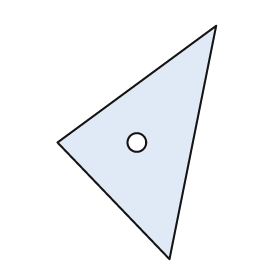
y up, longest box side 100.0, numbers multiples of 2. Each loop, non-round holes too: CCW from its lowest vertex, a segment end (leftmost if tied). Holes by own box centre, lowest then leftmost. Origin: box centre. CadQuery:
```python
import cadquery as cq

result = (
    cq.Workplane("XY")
    .moveTo(14.0, -50.0)
    .lineTo(34.0, 50.0)
    .lineTo(-34.0, 0.0)
    .close()
    .moveTo(0.0, 0.0)
    .circle(4.0)
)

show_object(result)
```